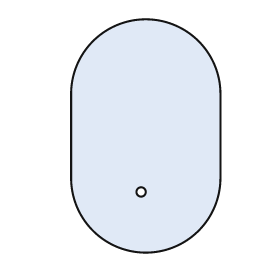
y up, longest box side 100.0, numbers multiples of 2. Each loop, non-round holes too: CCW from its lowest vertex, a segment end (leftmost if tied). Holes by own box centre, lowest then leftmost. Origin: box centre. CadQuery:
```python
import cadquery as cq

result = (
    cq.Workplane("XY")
    .moveTo(-32.0, -18.0)
    .threePointArc((0.0, -50.0), (32.0, -18.0))
    .lineTo(32.0, 18.0)
    .threePointArc((0.0, 50.0), (-32.0, 18.0))
    .close()
    .moveTo(-2.0, -24.0)
    .circle(2.0)
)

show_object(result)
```